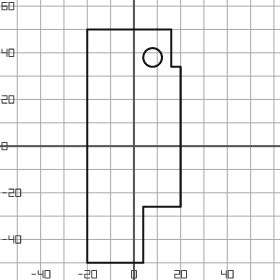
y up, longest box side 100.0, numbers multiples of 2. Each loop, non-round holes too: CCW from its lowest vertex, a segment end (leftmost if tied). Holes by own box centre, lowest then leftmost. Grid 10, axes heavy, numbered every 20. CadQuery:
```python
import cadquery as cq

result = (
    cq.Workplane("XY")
    .moveTo(-20.0, -50.0)
    .lineTo(4.0, -50.0)
    .lineTo(4.0, -26.0)
    .lineTo(20.0, -26.0)
    .lineTo(20.0, 34.0)
    .lineTo(16.0, 34.0)
    .lineTo(16.0, 50.0)
    .lineTo(-20.0, 50.0)
    .close()
    .moveTo(8.0, 38.0)
    .circle(4.0)
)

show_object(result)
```